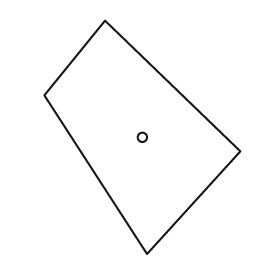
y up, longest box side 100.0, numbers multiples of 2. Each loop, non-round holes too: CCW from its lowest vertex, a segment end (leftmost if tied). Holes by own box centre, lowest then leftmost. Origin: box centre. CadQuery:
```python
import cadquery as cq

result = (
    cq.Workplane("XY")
    .moveTo(2.0, -50.0)
    .lineTo(42.0, -6.0)
    .lineTo(-16.0, 50.0)
    .lineTo(-42.0, 18.0)
    .close()
    .moveTo(0.0, 0.0)
    .circle(2.0)
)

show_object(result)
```